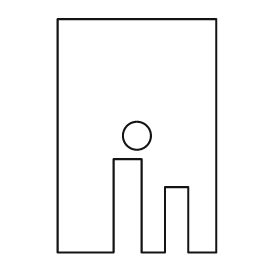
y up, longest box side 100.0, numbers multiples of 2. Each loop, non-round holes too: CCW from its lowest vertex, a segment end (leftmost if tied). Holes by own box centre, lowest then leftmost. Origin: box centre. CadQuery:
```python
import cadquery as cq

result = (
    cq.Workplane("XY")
    .moveTo(-34.0, -50.0)
    .lineTo(-10.0, -50.0)
    .lineTo(-10.0, -10.0)
    .lineTo(2.0, -10.0)
    .lineTo(2.0, -50.0)
    .lineTo(12.0, -50.0)
    .lineTo(12.0, -22.0)
    .lineTo(22.0, -22.0)
    .lineTo(22.0, -50.0)
    .lineTo(34.0, -50.0)
    .lineTo(34.0, 50.0)
    .lineTo(-34.0, 50.0)
    .close()
    .moveTo(0.0, 0.0)
    .circle(6.0)
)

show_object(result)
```